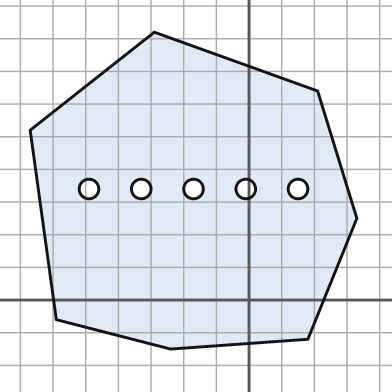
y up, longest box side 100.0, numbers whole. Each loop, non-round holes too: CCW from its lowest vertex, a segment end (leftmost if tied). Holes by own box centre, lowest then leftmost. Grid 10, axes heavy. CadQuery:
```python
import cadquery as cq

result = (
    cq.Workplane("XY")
    .moveTo(-24.0, -15.0)
    .lineTo(18.0, -12.0)
    .lineTo(33.0, 25.0)
    .lineTo(21.0, 64.0)
    .lineTo(-29.0, 82.0)
    .lineTo(-67.0, 52.0)
    .lineTo(-59.0, -6.0)
    .close()
    .moveTo(-49.0, 34.0)
    .circle(3.0)
    .moveTo(-33.0, 34.0)
    .circle(3.0)
    .moveTo(-17.0, 34.0)
    .circle(3.0)
    .moveTo(-1.0, 34.0)
    .circle(3.0)
    .moveTo(15.0, 34.0)
    .circle(3.0)
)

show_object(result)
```